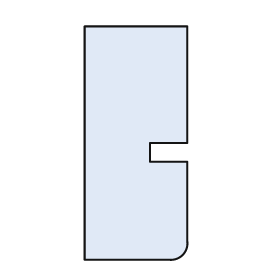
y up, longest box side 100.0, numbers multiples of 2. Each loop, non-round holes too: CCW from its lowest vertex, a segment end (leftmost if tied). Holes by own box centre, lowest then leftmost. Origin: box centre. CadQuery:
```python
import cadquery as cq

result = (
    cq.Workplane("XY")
    .moveTo(-22.0, -50.0)
    .lineTo(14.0, -50.0)
    .threePointArc((20.0, -48.0), (22.0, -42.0))
    .lineTo(22.0, -8.0)
    .lineTo(6.0, -8.0)
    .lineTo(6.0, 0.0)
    .lineTo(22.0, 0.0)
    .lineTo(22.0, 50.0)
    .lineTo(-22.0, 50.0)
    .close()
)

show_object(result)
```